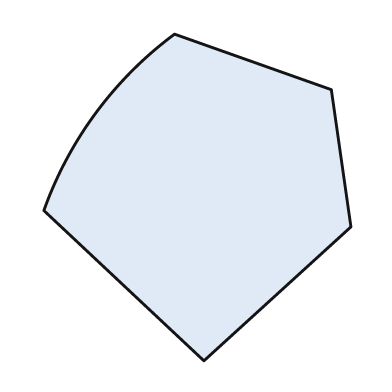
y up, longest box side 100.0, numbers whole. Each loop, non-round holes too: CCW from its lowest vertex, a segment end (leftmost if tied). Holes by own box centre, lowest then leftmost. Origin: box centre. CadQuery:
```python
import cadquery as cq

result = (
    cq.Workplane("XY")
    .moveTo(2.0, -50.0)
    .lineTo(47.0, -9.0)
    .lineTo(41.0, 33.0)
    .lineTo(-7.0, 50.0)
    .threePointArc((-31.0, 26.0), (-47.0, -4.0))
    .close()
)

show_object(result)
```